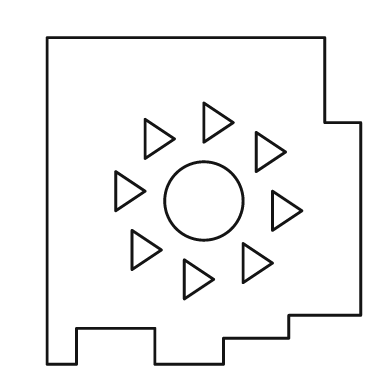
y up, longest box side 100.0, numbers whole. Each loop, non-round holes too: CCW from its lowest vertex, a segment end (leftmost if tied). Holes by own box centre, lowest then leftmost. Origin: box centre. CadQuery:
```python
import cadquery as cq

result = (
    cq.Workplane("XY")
    .moveTo(-48.0, -50.0)
    .lineTo(-39.0, -50.0)
    .lineTo(-39.0, -39.0)
    .lineTo(-15.0, -39.0)
    .lineTo(-15.0, -50.0)
    .lineTo(6.0, -50.0)
    .lineTo(6.0, -42.0)
    .lineTo(26.0, -42.0)
    .lineTo(26.0, -35.0)
    .lineTo(48.0, -35.0)
    .lineTo(48.0, 24.0)
    .lineTo(37.0, 24.0)
    .lineTo(37.0, 50.0)
    .lineTo(-48.0, 50.0)
    .close()
    .moveTo(-6.0, -30.0)
    .lineTo(3.0, -24.0)
    .lineTo(-6.0, -18.0)
    .close()
    .moveTo(12.0, -25.0)
    .lineTo(21.0, -19.0)
    .lineTo(12.0, -13.0)
    .close()
    .moveTo(-22.0, -21.0)
    .lineTo(-13.0, -15.0)
    .lineTo(-22.0, -9.0)
    .close()
    .moveTo(21.0, -9.0)
    .lineTo(30.0, -3.0)
    .lineTo(21.0, 3.0)
    .close()
    .moveTo(0.0, 0.0)
    .circle(12.0)
    .moveTo(-27.0, -3.0)
    .lineTo(-18.0, 3.0)
    .lineTo(-27.0, 9.0)
    .close()
    .moveTo(16.0, 9.0)
    .lineTo(25.0, 15.0)
    .lineTo(16.0, 21.0)
    .close()
    .moveTo(-18.0, 13.0)
    .lineTo(-9.0, 19.0)
    .lineTo(-18.0, 25.0)
    .close()
    .moveTo(0.0, 18.0)
    .lineTo(9.0, 24.0)
    .lineTo(0.0, 30.0)
    .close()
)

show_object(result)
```